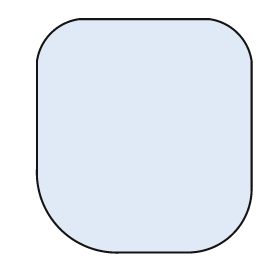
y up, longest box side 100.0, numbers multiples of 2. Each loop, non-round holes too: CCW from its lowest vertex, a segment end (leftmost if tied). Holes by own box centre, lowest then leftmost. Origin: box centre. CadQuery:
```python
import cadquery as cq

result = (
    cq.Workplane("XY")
    .moveTo(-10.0, -50.0)
    .lineTo(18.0, -50.0)
    .threePointArc((38.0, -42.0), (46.0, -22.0))
    .lineTo(46.0, 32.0)
    .threePointArc((40.0, 44.0), (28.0, 50.0))
    .lineTo(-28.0, 50.0)
    .threePointArc((-40.0, 44.0), (-46.0, 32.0))
    .lineTo(-46.0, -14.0)
    .threePointArc((-36.0, -40.0), (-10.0, -50.0))
    .close()
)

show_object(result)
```